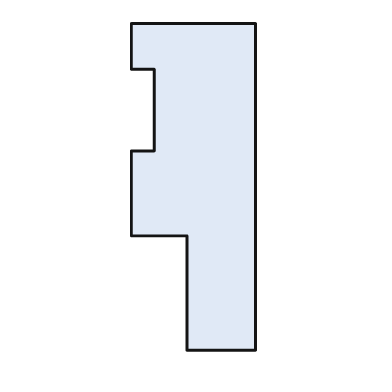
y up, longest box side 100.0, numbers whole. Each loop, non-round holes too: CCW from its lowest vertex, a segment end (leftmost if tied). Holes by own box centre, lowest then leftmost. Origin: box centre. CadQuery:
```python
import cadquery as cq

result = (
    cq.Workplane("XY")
    .moveTo(-2.0, -50.0)
    .lineTo(19.0, -50.0)
    .lineTo(19.0, 50.0)
    .lineTo(-19.0, 50.0)
    .lineTo(-19.0, 36.0)
    .lineTo(-12.0, 36.0)
    .lineTo(-12.0, 11.0)
    .lineTo(-19.0, 11.0)
    .lineTo(-19.0, -15.0)
    .lineTo(-2.0, -15.0)
    .close()
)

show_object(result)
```